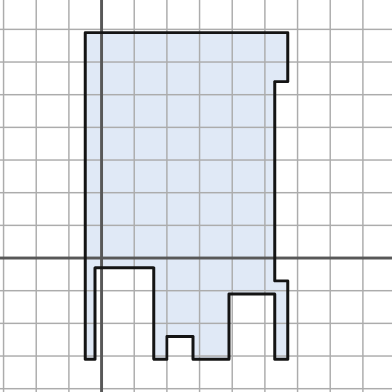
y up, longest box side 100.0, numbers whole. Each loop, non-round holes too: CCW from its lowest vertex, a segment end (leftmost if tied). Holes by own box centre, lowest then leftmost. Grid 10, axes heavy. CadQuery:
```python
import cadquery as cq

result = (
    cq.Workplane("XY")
    .moveTo(-5.0, -31.0)
    .lineTo(-2.0, -31.0)
    .lineTo(-2.0, -3.0)
    .lineTo(16.0, -3.0)
    .lineTo(16.0, -31.0)
    .lineTo(20.0, -31.0)
    .lineTo(20.0, -24.0)
    .lineTo(28.0, -24.0)
    .lineTo(28.0, -31.0)
    .lineTo(39.0, -31.0)
    .lineTo(39.0, -11.0)
    .lineTo(53.0, -11.0)
    .lineTo(53.0, -31.0)
    .lineTo(57.0, -31.0)
    .lineTo(57.0, -7.0)
    .lineTo(53.0, -7.0)
    .lineTo(53.0, 54.0)
    .lineTo(57.0, 54.0)
    .lineTo(57.0, 69.0)
    .lineTo(-5.0, 69.0)
    .close()
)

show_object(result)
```